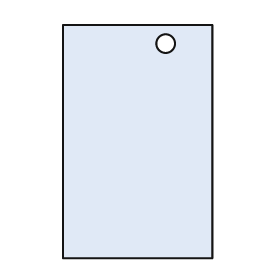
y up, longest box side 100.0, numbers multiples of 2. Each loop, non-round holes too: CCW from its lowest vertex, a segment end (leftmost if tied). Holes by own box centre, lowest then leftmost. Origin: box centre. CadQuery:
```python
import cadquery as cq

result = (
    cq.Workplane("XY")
    .moveTo(-32.0, -50.0)
    .lineTo(32.0, -50.0)
    .lineTo(32.0, 50.0)
    .lineTo(-32.0, 50.0)
    .close()
    .moveTo(12.0, 42.0)
    .circle(4.0)
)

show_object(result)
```